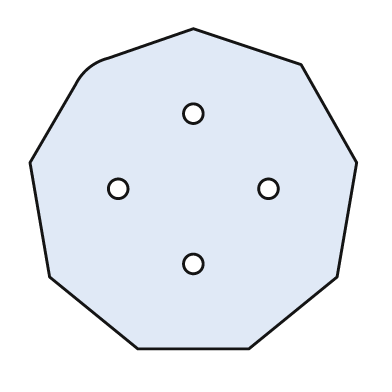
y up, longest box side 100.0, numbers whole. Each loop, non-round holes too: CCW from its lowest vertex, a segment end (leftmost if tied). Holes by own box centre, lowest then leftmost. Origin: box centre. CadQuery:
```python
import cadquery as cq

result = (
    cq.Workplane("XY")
    .moveTo(-17.0, -49.0)
    .lineTo(17.0, -49.0)
    .lineTo(44.0, -27.0)
    .lineTo(50.0, 8.0)
    .lineTo(33.0, 38.0)
    .lineTo(0.0, 49.0)
    .lineTo(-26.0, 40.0)
    .threePointArc((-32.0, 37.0), (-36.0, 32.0))
    .lineTo(-50.0, 8.0)
    .lineTo(-44.0, -27.0)
    .close()
    .moveTo(0.0, -23.0)
    .circle(3.0)
    .moveTo(-23.0, 0.0)
    .circle(3.0)
    .moveTo(23.0, 0.0)
    .circle(3.0)
    .moveTo(0.0, 23.0)
    .circle(3.0)
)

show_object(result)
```